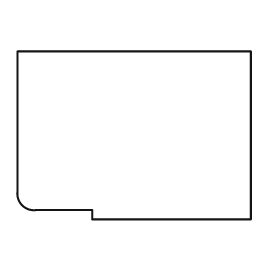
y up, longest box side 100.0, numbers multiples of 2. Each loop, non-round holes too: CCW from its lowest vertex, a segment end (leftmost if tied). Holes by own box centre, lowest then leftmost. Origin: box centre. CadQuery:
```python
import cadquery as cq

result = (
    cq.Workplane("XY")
    .moveTo(-18.0, -36.0)
    .lineTo(50.0, -36.0)
    .lineTo(50.0, 36.0)
    .lineTo(-50.0, 36.0)
    .lineTo(-50.0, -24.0)
    .threePointArc((-48.0, -30.0), (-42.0, -32.0))
    .lineTo(-18.0, -32.0)
    .close()
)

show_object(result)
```